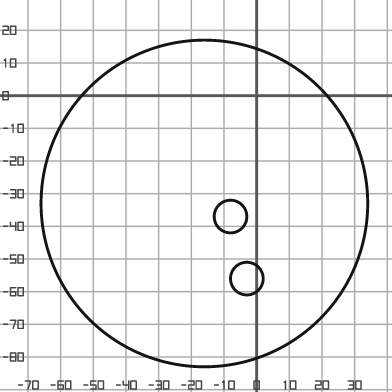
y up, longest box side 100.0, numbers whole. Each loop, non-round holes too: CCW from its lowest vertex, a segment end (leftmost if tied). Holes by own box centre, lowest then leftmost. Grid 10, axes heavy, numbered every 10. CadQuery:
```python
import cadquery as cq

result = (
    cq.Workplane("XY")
    .moveTo(-16.0, -33.0)
    .circle(50.0)
    .moveTo(-3.0, -56.0)
    .circle(5.0)
    .moveTo(-8.0, -37.0)
    .circle(5.0)
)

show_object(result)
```